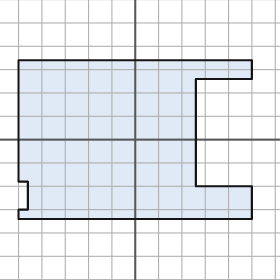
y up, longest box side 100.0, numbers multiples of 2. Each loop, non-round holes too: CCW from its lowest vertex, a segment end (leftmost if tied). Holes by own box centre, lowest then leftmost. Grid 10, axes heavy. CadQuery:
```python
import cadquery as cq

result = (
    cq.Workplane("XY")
    .moveTo(-50.0, -34.0)
    .lineTo(50.0, -34.0)
    .lineTo(50.0, -20.0)
    .lineTo(26.0, -20.0)
    .lineTo(26.0, 26.0)
    .lineTo(50.0, 26.0)
    .lineTo(50.0, 34.0)
    .lineTo(-50.0, 34.0)
    .lineTo(-50.0, -18.0)
    .lineTo(-46.0, -18.0)
    .lineTo(-46.0, -30.0)
    .lineTo(-50.0, -30.0)
    .close()
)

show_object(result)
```